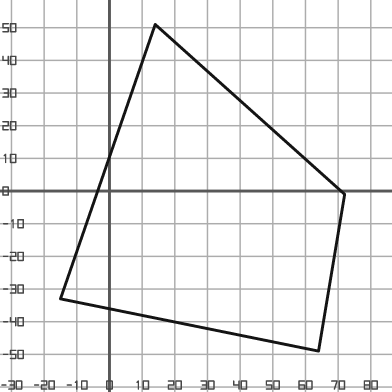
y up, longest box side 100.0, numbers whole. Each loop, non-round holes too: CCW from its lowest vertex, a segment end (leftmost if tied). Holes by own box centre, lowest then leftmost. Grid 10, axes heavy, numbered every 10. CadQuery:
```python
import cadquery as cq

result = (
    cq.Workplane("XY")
    .moveTo(64.0, -49.0)
    .lineTo(72.0, -1.0)
    .lineTo(14.0, 51.0)
    .lineTo(-15.0, -33.0)
    .close()
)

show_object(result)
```